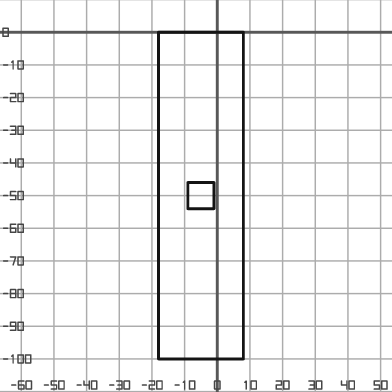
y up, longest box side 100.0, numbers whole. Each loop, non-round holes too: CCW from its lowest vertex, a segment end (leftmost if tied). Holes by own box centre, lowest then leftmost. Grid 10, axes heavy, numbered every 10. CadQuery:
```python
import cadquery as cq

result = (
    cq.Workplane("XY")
    .moveTo(-18.0, -100.0)
    .lineTo(8.0, -100.0)
    .lineTo(8.0, 0.0)
    .lineTo(-18.0, 0.0)
    .close()
    .moveTo(-9.0, -54.0)
    .lineTo(-1.0, -54.0)
    .lineTo(-1.0, -46.0)
    .lineTo(-9.0, -46.0)
    .close()
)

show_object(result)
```